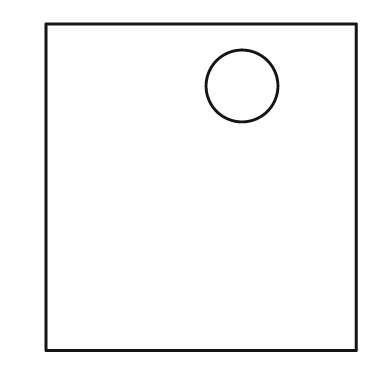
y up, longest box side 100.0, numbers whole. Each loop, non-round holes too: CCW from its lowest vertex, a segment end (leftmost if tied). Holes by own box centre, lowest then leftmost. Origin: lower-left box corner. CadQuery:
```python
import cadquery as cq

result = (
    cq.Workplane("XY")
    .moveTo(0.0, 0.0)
    .lineTo(95.0, 0.0)
    .lineTo(95.0, 100.0)
    .lineTo(0.0, 100.0)
    .close()
    .moveTo(60.0, 81.0)
    .circle(11.0)
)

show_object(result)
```